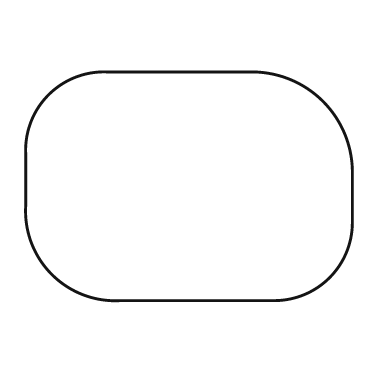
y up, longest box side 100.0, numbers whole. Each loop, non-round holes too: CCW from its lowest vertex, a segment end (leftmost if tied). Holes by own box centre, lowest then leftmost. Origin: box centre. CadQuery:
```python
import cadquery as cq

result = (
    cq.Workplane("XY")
    .moveTo(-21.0, -35.0)
    .lineTo(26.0, -35.0)
    .threePointArc((43.0, -28.0), (50.0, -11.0))
    .lineTo(50.0, 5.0)
    .threePointArc((41.0, 26.0), (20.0, 35.0))
    .lineTo(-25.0, 35.0)
    .threePointArc((-43.0, 28.0), (-50.0, 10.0))
    .lineTo(-50.0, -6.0)
    .threePointArc((-42.0, -27.0), (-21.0, -35.0))
    .close()
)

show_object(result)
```